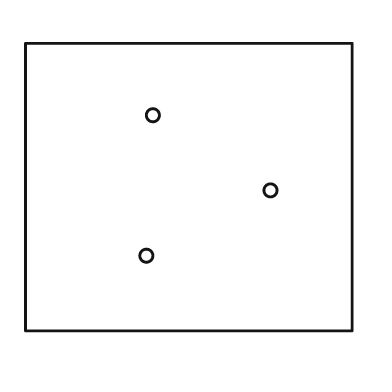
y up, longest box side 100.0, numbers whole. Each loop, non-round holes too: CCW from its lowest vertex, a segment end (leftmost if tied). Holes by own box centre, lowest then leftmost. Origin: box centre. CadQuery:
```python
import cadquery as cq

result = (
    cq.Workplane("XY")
    .moveTo(-50.0, -44.0)
    .lineTo(50.0, -44.0)
    .lineTo(50.0, 44.0)
    .lineTo(-50.0, 44.0)
    .close()
    .moveTo(-13.0, -21.0)
    .circle(2.0)
    .moveTo(25.0, -1.0)
    .circle(2.0)
    .moveTo(-11.0, 22.0)
    .circle(2.0)
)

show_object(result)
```